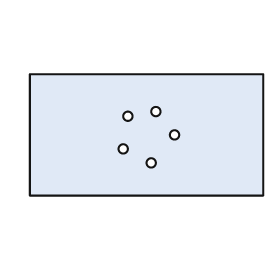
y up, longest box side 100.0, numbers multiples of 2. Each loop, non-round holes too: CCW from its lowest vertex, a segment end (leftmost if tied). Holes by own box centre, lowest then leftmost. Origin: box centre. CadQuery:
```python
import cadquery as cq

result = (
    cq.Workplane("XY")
    .moveTo(-50.0, -26.0)
    .lineTo(50.0, -26.0)
    .lineTo(50.0, 26.0)
    .lineTo(-50.0, 26.0)
    .close()
    .moveTo(2.0, -12.0)
    .circle(2.0)
    .moveTo(-10.0, -6.0)
    .circle(2.0)
    .moveTo(12.0, 0.0)
    .circle(2.0)
    .moveTo(-8.0, 8.0)
    .circle(2.0)
    .moveTo(4.0, 10.0)
    .circle(2.0)
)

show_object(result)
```